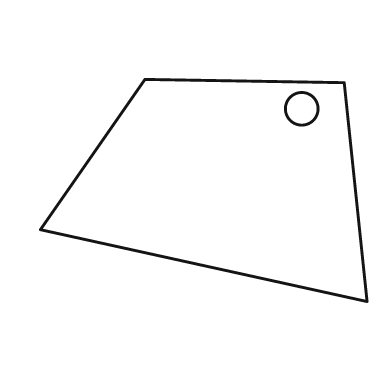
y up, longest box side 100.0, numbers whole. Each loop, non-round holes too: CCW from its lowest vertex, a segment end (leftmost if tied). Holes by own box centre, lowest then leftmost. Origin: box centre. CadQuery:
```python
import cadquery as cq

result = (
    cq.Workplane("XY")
    .moveTo(50.0, -34.0)
    .lineTo(43.0, 33.0)
    .lineTo(-18.0, 34.0)
    .lineTo(-50.0, -12.0)
    .close()
    .moveTo(30.0, 25.0)
    .circle(5.0)
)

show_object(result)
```